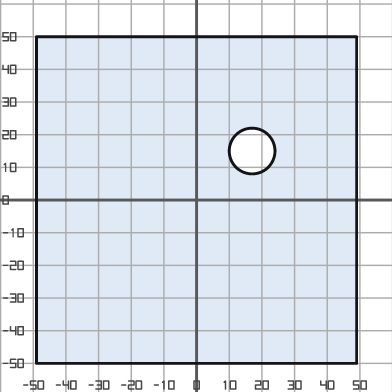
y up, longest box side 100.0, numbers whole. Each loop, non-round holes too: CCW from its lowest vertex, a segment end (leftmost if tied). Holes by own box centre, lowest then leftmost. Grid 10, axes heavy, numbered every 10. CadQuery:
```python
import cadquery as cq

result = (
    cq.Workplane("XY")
    .moveTo(-49.0, -50.0)
    .lineTo(49.0, -50.0)
    .lineTo(49.0, 50.0)
    .lineTo(-49.0, 50.0)
    .close()
    .moveTo(17.0, 15.0)
    .circle(7.0)
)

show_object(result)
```